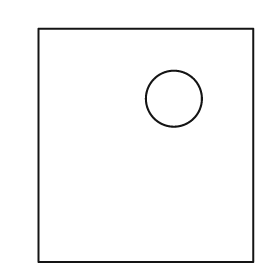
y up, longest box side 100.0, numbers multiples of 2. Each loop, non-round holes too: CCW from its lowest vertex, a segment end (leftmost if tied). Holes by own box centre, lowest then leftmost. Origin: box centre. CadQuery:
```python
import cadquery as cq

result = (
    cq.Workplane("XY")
    .moveTo(-46.0, -50.0)
    .lineTo(46.0, -50.0)
    .lineTo(46.0, 50.0)
    .lineTo(-46.0, 50.0)
    .close()
    .moveTo(12.0, 20.0)
    .circle(12.0)
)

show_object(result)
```